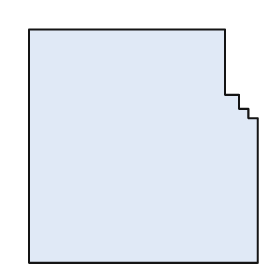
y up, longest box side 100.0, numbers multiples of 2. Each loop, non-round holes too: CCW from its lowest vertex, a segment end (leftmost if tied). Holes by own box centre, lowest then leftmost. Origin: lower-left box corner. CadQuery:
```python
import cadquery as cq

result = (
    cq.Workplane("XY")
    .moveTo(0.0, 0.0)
    .lineTo(98.0, 0.0)
    .lineTo(98.0, 62.0)
    .lineTo(94.0, 62.0)
    .lineTo(94.0, 66.0)
    .lineTo(90.0, 66.0)
    .lineTo(90.0, 72.0)
    .lineTo(84.0, 72.0)
    .lineTo(84.0, 100.0)
    .lineTo(0.0, 100.0)
    .close()
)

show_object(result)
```